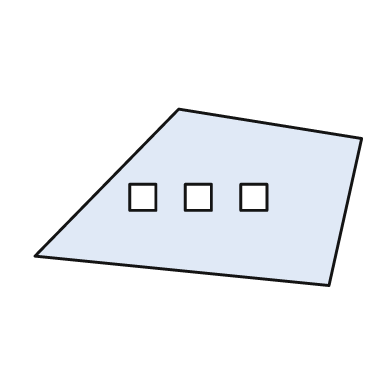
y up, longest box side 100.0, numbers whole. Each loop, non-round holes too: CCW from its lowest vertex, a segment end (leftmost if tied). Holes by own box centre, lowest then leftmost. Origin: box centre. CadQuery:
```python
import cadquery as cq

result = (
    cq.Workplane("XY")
    .moveTo(40.0, -27.0)
    .lineTo(50.0, 18.0)
    .lineTo(-6.0, 27.0)
    .lineTo(-50.0, -18.0)
    .close()
    .moveTo(-21.0, -4.0)
    .lineTo(-13.0, -4.0)
    .lineTo(-13.0, 4.0)
    .lineTo(-21.0, 4.0)
    .close()
    .moveTo(-4.0, -4.0)
    .lineTo(4.0, -4.0)
    .lineTo(4.0, 4.0)
    .lineTo(-4.0, 4.0)
    .close()
    .moveTo(13.0, -4.0)
    .lineTo(21.0, -4.0)
    .lineTo(21.0, 4.0)
    .lineTo(13.0, 4.0)
    .close()
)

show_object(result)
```